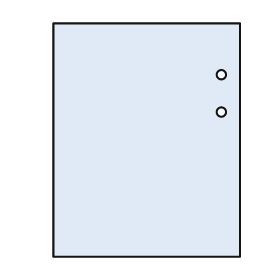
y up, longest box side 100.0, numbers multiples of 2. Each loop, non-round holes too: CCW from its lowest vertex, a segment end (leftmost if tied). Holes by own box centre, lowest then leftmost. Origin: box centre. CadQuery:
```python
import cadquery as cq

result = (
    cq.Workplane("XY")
    .moveTo(-40.0, -50.0)
    .lineTo(40.0, -50.0)
    .lineTo(40.0, 50.0)
    .lineTo(-40.0, 50.0)
    .close()
    .moveTo(32.0, 12.0)
    .circle(2.0)
    .moveTo(32.0, 28.0)
    .circle(2.0)
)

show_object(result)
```